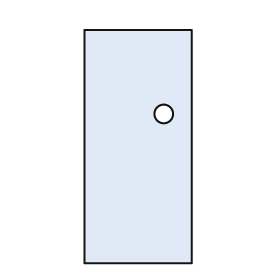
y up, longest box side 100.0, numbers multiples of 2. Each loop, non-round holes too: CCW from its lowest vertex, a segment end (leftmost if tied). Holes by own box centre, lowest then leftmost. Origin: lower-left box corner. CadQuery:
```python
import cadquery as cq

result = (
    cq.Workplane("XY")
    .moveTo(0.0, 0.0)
    .lineTo(46.0, 0.0)
    .lineTo(46.0, 100.0)
    .lineTo(0.0, 100.0)
    .close()
    .moveTo(34.0, 64.0)
    .circle(4.0)
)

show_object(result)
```